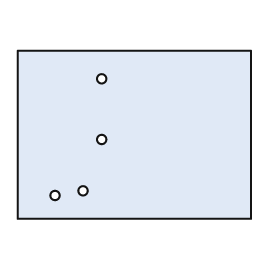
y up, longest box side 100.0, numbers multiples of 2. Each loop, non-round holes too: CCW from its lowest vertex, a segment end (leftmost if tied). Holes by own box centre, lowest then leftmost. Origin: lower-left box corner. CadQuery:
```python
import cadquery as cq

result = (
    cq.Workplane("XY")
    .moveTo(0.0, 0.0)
    .lineTo(100.0, 0.0)
    .lineTo(100.0, 72.0)
    .lineTo(0.0, 72.0)
    .close()
    .moveTo(16.0, 10.0)
    .circle(2.0)
    .moveTo(28.0, 12.0)
    .circle(2.0)
    .moveTo(36.0, 34.0)
    .circle(2.0)
    .moveTo(36.0, 60.0)
    .circle(2.0)
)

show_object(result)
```